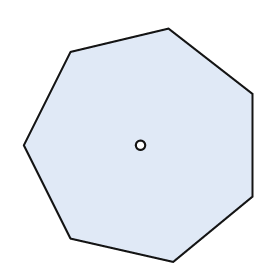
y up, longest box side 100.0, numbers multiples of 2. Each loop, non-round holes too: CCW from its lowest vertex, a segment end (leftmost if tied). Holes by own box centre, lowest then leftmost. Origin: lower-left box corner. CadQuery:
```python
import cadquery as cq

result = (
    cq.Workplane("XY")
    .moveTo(64.0, 0.0)
    .lineTo(98.0, 28.0)
    .lineTo(98.0, 72.0)
    .lineTo(62.0, 100.0)
    .lineTo(20.0, 90.0)
    .lineTo(0.0, 50.0)
    .lineTo(20.0, 10.0)
    .close()
    .moveTo(50.0, 50.0)
    .circle(2.0)
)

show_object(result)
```